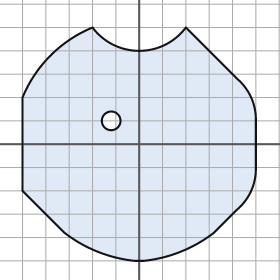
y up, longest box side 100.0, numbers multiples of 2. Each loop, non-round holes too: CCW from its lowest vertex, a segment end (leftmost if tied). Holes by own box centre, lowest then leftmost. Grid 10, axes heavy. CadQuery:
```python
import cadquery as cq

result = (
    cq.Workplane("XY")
    .moveTo(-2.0, -50.0)
    .lineTo(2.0, -50.0)
    .threePointArc((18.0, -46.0), (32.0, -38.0))
    .lineTo(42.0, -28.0)
    .threePointArc((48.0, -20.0), (50.0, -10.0))
    .lineTo(50.0, 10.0)
    .threePointArc((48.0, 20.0), (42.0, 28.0))
    .lineTo(20.0, 50.0)
    .threePointArc((0.0, 40.0), (-20.0, 50.0))
    .threePointArc((-38.0, 38.0), (-50.0, 20.0))
    .lineTo(-50.0, -20.0)
    .lineTo(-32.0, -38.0)
    .threePointArc((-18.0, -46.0), (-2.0, -50.0))
    .close()
    .moveTo(-12.0, 10.0)
    .circle(4.0)
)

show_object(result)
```